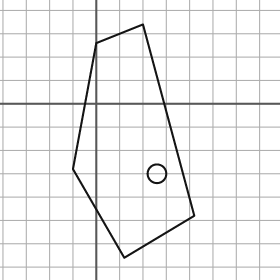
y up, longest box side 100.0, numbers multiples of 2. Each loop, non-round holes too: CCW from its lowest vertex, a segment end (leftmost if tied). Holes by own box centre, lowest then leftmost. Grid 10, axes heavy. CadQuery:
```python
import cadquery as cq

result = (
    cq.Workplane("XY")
    .moveTo(12.0, -66.0)
    .lineTo(42.0, -48.0)
    .lineTo(20.0, 34.0)
    .lineTo(0.0, 26.0)
    .lineTo(-10.0, -28.0)
    .close()
    .moveTo(26.0, -30.0)
    .circle(4.0)
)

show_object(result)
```